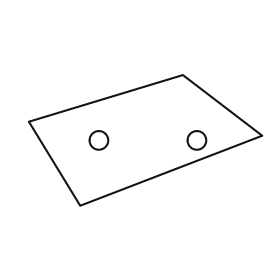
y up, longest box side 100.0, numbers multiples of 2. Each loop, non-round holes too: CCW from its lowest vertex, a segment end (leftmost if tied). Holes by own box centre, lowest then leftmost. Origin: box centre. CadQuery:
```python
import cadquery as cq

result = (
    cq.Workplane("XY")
    .moveTo(-28.0, -28.0)
    .lineTo(50.0, 2.0)
    .lineTo(16.0, 28.0)
    .lineTo(-50.0, 8.0)
    .close()
    .moveTo(-20.0, 0.0)
    .circle(4.0)
    .moveTo(22.0, 0.0)
    .circle(4.0)
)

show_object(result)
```